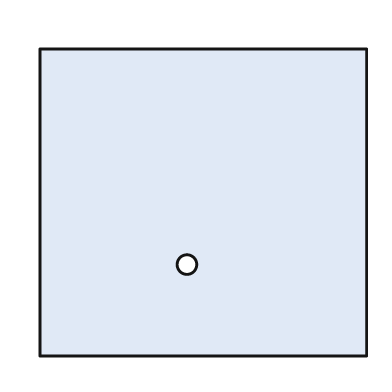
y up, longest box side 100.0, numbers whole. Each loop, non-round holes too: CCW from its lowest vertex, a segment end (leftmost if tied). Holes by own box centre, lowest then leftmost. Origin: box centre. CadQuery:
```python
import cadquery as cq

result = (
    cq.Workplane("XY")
    .moveTo(-50.0, -47.0)
    .lineTo(50.0, -47.0)
    .lineTo(50.0, 47.0)
    .lineTo(-50.0, 47.0)
    .close()
    .moveTo(-5.0, -19.0)
    .circle(3.0)
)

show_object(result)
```